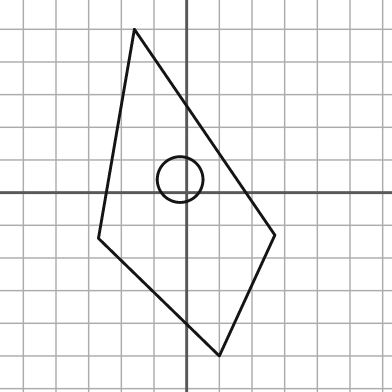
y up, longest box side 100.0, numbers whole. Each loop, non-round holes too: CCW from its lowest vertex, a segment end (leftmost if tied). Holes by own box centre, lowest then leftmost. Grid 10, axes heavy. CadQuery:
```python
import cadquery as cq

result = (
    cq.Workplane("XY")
    .moveTo(10.0, -50.0)
    .lineTo(27.0, -13.0)
    .lineTo(-16.0, 50.0)
    .lineTo(-27.0, -14.0)
    .close()
    .moveTo(-2.0, 4.0)
    .circle(7.0)
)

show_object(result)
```